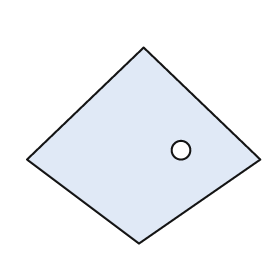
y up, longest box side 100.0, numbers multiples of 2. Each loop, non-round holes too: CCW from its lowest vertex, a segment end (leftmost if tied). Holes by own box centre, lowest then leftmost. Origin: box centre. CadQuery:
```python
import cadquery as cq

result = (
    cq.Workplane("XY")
    .moveTo(-2.0, -42.0)
    .lineTo(50.0, -6.0)
    .lineTo(0.0, 42.0)
    .lineTo(-50.0, -6.0)
    .close()
    .moveTo(16.0, -2.0)
    .circle(4.0)
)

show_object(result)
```